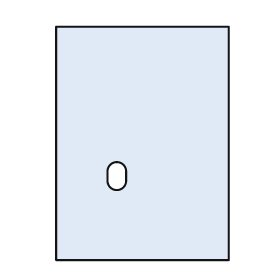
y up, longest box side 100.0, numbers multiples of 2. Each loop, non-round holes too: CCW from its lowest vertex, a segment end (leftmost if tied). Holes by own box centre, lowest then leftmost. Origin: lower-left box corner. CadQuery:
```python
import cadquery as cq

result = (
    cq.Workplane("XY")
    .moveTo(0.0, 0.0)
    .lineTo(74.0, 0.0)
    .lineTo(74.0, 100.0)
    .lineTo(0.0, 100.0)
    .close()
    .moveTo(22.0, 34.0)
    .threePointArc((26.0, 30.0), (30.0, 34.0))
    .lineTo(30.0, 38.0)
    .threePointArc((26.0, 42.0), (22.0, 38.0))
    .close()
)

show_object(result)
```